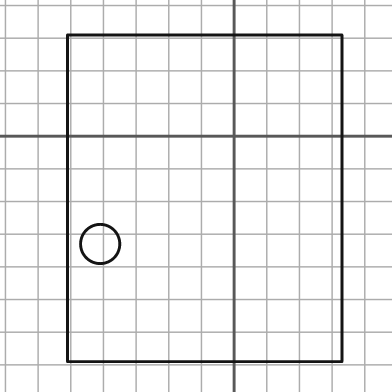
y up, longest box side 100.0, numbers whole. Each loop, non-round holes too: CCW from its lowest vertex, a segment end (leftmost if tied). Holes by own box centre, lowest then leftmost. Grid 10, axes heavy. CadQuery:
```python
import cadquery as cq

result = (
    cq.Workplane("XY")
    .moveTo(-51.0, -69.0)
    .lineTo(33.0, -69.0)
    .lineTo(33.0, 31.0)
    .lineTo(-51.0, 31.0)
    .close()
    .moveTo(-41.0, -33.0)
    .circle(6.0)
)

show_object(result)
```